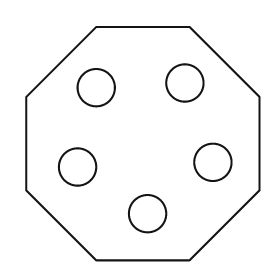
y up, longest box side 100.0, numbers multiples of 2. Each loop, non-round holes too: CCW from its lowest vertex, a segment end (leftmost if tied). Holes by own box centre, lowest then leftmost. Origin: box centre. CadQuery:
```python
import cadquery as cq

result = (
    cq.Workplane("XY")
    .moveTo(-20.0, -50.0)
    .lineTo(20.0, -50.0)
    .lineTo(50.0, -20.0)
    .lineTo(50.0, 20.0)
    .lineTo(20.0, 50.0)
    .lineTo(-20.0, 50.0)
    .lineTo(-50.0, 20.0)
    .lineTo(-50.0, -20.0)
    .close()
    .moveTo(2.0, -30.0)
    .circle(8.0)
    .moveTo(-28.0, -10.0)
    .circle(8.0)
    .moveTo(30.0, -8.0)
    .circle(8.0)
    .moveTo(-20.0, 24.0)
    .circle(8.0)
    .moveTo(18.0, 26.0)
    .circle(8.0)
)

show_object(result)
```